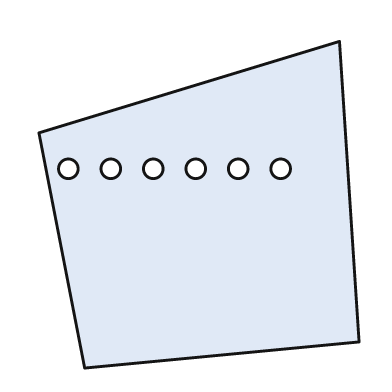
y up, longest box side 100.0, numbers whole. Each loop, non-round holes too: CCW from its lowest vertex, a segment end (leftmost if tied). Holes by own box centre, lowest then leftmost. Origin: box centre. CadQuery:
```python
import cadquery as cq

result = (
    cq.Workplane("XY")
    .moveTo(-35.0, -50.0)
    .lineTo(49.0, -42.0)
    .lineTo(43.0, 50.0)
    .lineTo(-49.0, 22.0)
    .close()
    .moveTo(-40.0, 11.0)
    .circle(3.0)
    .moveTo(-27.0, 11.0)
    .circle(3.0)
    .moveTo(-14.0, 11.0)
    .circle(3.0)
    .moveTo(-1.0, 11.0)
    .circle(3.0)
    .moveTo(12.0, 11.0)
    .circle(3.0)
    .moveTo(25.0, 11.0)
    .circle(3.0)
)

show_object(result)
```